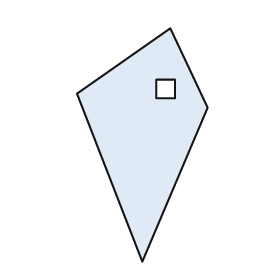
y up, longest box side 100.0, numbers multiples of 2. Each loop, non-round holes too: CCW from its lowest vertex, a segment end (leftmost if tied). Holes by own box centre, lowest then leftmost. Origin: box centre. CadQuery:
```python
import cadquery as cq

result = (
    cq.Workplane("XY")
    .moveTo(0.0, -50.0)
    .lineTo(28.0, 16.0)
    .lineTo(12.0, 50.0)
    .lineTo(-28.0, 22.0)
    .close()
    .moveTo(6.0, 20.0)
    .lineTo(14.0, 20.0)
    .lineTo(14.0, 28.0)
    .lineTo(6.0, 28.0)
    .close()
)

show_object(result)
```